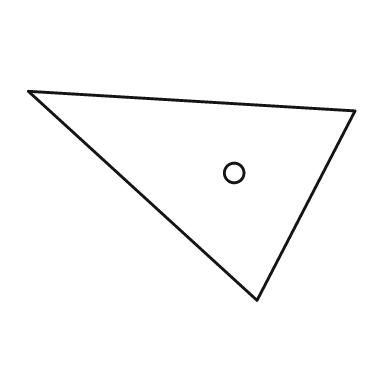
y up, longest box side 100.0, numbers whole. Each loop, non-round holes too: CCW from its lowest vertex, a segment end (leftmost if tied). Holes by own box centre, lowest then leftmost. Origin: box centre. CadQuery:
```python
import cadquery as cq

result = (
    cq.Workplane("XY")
    .moveTo(20.0, -32.0)
    .lineTo(50.0, 26.0)
    .lineTo(-50.0, 32.0)
    .close()
    .moveTo(13.0, 7.0)
    .circle(3.0)
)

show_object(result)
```